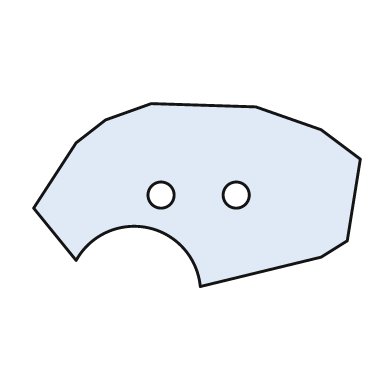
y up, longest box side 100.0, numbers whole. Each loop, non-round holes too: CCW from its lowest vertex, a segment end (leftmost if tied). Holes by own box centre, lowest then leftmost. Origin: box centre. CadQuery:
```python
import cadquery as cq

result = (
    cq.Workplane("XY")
    .moveTo(1.0, -28.0)
    .lineTo(38.0, -19.0)
    .lineTo(46.0, -14.0)
    .lineTo(50.0, 11.0)
    .lineTo(38.0, 20.0)
    .lineTo(18.0, 27.0)
    .lineTo(-14.0, 28.0)
    .lineTo(-28.0, 23.0)
    .lineTo(-37.0, 16.0)
    .lineTo(-50.0, -4.0)
    .lineTo(-37.0, -20.0)
    .threePointArc((-15.0, -10.0), (1.0, -28.0))
    .close()
    .moveTo(-11.0, 0.0)
    .circle(4.0)
    .moveTo(12.0, 0.0)
    .circle(4.0)
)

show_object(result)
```